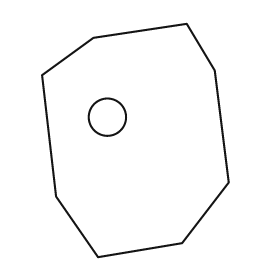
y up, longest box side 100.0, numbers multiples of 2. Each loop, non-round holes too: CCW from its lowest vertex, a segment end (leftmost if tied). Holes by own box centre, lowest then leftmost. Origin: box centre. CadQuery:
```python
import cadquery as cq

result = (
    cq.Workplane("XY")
    .moveTo(-16.0, -50.0)
    .lineTo(20.0, -44.0)
    .lineTo(40.0, -18.0)
    .lineTo(34.0, 30.0)
    .lineTo(22.0, 50.0)
    .lineTo(-18.0, 44.0)
    .lineTo(-40.0, 28.0)
    .lineTo(-34.0, -24.0)
    .close()
    .moveTo(-12.0, 10.0)
    .circle(8.0)
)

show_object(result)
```